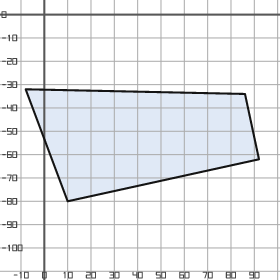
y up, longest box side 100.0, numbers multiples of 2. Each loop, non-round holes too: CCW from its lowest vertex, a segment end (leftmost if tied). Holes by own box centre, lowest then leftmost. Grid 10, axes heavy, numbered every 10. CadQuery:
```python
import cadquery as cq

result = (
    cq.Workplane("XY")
    .moveTo(10.0, -80.0)
    .lineTo(92.0, -62.0)
    .lineTo(86.0, -34.0)
    .lineTo(-8.0, -32.0)
    .close()
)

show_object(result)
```